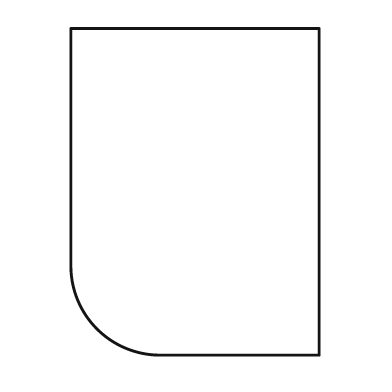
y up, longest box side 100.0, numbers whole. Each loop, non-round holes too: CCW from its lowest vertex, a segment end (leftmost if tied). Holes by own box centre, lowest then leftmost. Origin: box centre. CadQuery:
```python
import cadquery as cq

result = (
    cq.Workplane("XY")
    .moveTo(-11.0, -50.0)
    .lineTo(38.0, -50.0)
    .lineTo(38.0, 50.0)
    .lineTo(-38.0, 50.0)
    .lineTo(-38.0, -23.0)
    .threePointArc((-30.0, -42.0), (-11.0, -50.0))
    .close()
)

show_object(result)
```